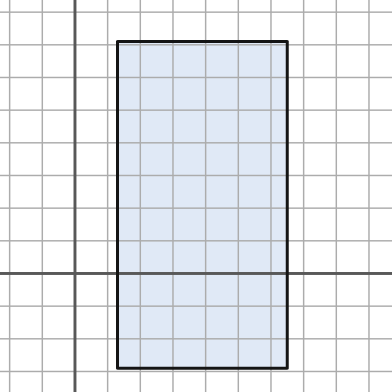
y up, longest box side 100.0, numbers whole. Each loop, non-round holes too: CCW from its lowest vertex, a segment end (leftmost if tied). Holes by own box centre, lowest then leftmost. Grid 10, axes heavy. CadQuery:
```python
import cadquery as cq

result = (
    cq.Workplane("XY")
    .moveTo(13.0, -29.0)
    .lineTo(65.0, -29.0)
    .lineTo(65.0, 71.0)
    .lineTo(13.0, 71.0)
    .close()
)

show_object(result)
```